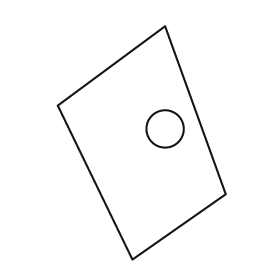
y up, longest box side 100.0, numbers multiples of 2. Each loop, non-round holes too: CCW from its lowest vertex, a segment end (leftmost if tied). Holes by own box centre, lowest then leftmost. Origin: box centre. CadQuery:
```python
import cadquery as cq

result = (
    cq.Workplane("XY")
    .moveTo(-4.0, -50.0)
    .lineTo(36.0, -22.0)
    .lineTo(10.0, 50.0)
    .lineTo(-36.0, 16.0)
    .close()
    .moveTo(10.0, 6.0)
    .circle(8.0)
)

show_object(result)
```